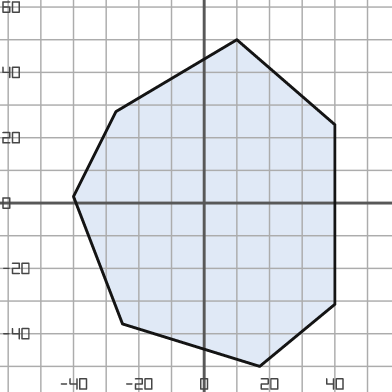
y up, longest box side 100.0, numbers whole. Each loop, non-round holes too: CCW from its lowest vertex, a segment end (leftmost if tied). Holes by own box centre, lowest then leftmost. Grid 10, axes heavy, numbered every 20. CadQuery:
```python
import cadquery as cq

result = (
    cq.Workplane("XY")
    .moveTo(17.0, -50.0)
    .lineTo(40.0, -31.0)
    .lineTo(40.0, 24.0)
    .lineTo(10.0, 50.0)
    .lineTo(-27.0, 28.0)
    .lineTo(-40.0, 2.0)
    .lineTo(-25.0, -37.0)
    .close()
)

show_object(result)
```